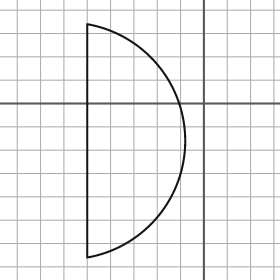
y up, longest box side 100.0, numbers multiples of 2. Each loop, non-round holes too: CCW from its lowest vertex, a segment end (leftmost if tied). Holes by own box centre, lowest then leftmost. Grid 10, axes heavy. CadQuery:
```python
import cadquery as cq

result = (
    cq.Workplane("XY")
    .moveTo(-50.0, -66.0)
    .threePointArc((-8.0, -16.0), (-50.0, 34.0))
    .close()
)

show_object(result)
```